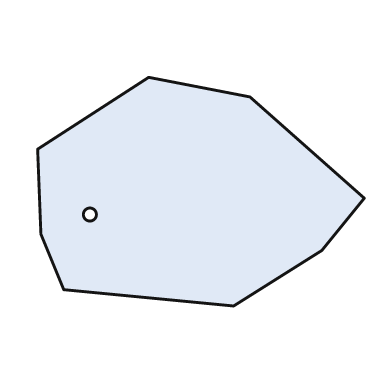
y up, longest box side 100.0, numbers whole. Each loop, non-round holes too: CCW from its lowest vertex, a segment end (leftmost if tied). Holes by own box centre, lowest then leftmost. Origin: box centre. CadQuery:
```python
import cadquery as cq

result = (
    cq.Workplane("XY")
    .moveTo(10.0, -35.0)
    .lineTo(37.0, -18.0)
    .lineTo(50.0, -2.0)
    .lineTo(15.0, 29.0)
    .lineTo(-16.0, 35.0)
    .lineTo(-50.0, 13.0)
    .lineTo(-49.0, -13.0)
    .lineTo(-42.0, -30.0)
    .close()
    .moveTo(-34.0, -7.0)
    .circle(2.0)
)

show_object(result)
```